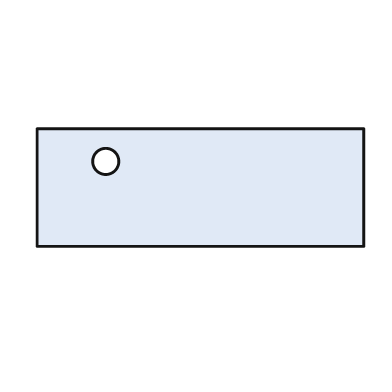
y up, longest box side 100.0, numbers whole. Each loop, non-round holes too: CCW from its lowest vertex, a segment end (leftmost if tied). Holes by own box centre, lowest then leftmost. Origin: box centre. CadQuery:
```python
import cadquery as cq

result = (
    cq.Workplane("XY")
    .moveTo(-50.0, -18.0)
    .lineTo(50.0, -18.0)
    .lineTo(50.0, 18.0)
    .lineTo(-50.0, 18.0)
    .close()
    .moveTo(-29.0, 8.0)
    .circle(4.0)
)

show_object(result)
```